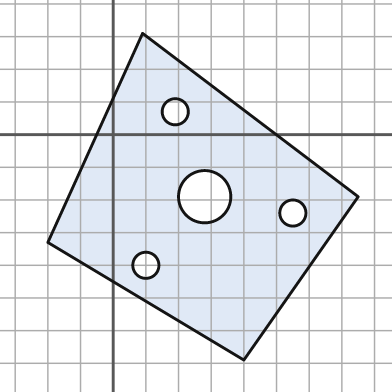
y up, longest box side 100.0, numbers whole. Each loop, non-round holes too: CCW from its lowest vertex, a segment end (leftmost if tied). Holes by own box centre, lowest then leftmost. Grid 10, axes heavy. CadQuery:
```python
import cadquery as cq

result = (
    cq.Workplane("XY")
    .moveTo(40.0, -69.0)
    .lineTo(75.0, -19.0)
    .lineTo(9.0, 31.0)
    .lineTo(-20.0, -33.0)
    .close()
    .moveTo(10.0, -40.0)
    .circle(4.0)
    .moveTo(55.0, -24.0)
    .circle(4.0)
    .moveTo(28.0, -19.0)
    .circle(8.0)
    .moveTo(19.0, 7.0)
    .circle(4.0)
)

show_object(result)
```